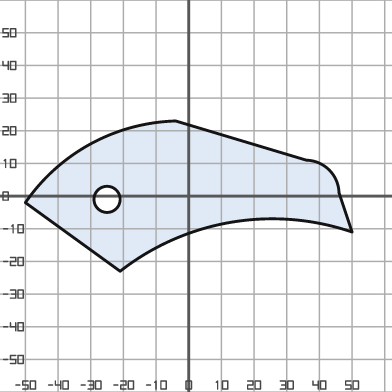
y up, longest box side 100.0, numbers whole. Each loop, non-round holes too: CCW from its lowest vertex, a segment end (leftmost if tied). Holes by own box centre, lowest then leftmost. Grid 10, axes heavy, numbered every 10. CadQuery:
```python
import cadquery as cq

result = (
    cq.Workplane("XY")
    .moveTo(-21.0, -23.0)
    .threePointArc((13.0, -8.0), (50.0, -11.0))
    .lineTo(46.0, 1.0)
    .threePointArc((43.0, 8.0), (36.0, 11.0))
    .lineTo(-4.0, 23.0)
    .threePointArc((-30.0, 16.0), (-50.0, -2.0))
    .close()
    .moveTo(-25.0, -1.0)
    .circle(4.0)
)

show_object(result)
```